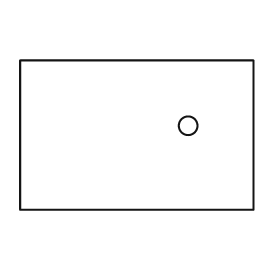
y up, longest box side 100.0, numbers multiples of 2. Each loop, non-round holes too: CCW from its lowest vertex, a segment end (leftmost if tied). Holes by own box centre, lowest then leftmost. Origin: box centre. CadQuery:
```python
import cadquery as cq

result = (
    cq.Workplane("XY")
    .moveTo(-50.0, -32.0)
    .lineTo(50.0, -32.0)
    .lineTo(50.0, 32.0)
    .lineTo(-50.0, 32.0)
    .close()
    .moveTo(22.0, 4.0)
    .circle(4.0)
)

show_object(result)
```